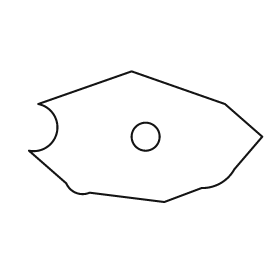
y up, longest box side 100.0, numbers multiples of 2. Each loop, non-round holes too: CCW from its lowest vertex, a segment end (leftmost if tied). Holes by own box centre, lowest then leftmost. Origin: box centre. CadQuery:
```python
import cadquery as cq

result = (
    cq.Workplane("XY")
    .moveTo(8.0, -28.0)
    .lineTo(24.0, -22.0)
    .threePointArc((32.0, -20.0), (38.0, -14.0))
    .lineTo(50.0, 0.0)
    .lineTo(34.0, 14.0)
    .lineTo(-6.0, 28.0)
    .lineTo(-46.0, 14.0)
    .threePointArc((-38.0, 2.0), (-50.0, -6.0))
    .lineTo(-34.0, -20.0)
    .threePointArc((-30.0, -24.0), (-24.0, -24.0))
    .close()
    .moveTo(0.0, 0.0)
    .circle(6.0)
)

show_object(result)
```